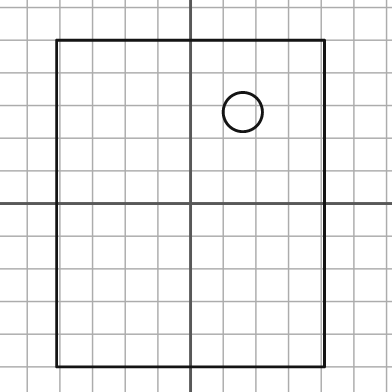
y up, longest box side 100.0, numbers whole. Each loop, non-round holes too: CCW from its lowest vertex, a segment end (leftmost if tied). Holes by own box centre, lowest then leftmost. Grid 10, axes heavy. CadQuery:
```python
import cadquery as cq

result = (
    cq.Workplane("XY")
    .moveTo(-41.0, -50.0)
    .lineTo(41.0, -50.0)
    .lineTo(41.0, 50.0)
    .lineTo(-41.0, 50.0)
    .close()
    .moveTo(16.0, 28.0)
    .circle(6.0)
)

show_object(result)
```